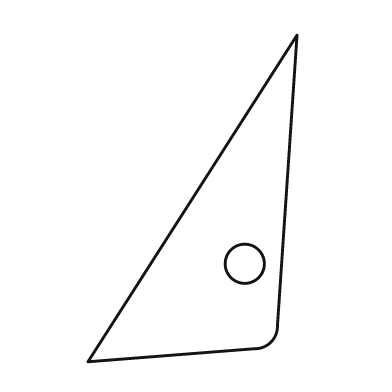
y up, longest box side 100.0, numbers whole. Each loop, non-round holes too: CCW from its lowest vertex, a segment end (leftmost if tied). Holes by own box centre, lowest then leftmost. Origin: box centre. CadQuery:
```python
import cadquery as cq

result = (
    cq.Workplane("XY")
    .moveTo(-32.0, -50.0)
    .lineTo(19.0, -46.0)
    .threePointArc((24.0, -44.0), (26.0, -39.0))
    .lineTo(32.0, 50.0)
    .close()
    .moveTo(16.0, -20.0)
    .circle(6.0)
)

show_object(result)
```